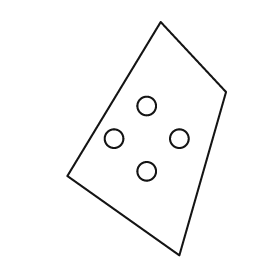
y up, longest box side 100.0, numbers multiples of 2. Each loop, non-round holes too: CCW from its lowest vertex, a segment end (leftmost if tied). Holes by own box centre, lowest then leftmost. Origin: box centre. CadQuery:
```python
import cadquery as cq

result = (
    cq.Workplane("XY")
    .moveTo(14.0, -50.0)
    .lineTo(34.0, 20.0)
    .lineTo(6.0, 50.0)
    .lineTo(-34.0, -16.0)
    .close()
    .moveTo(0.0, -14.0)
    .circle(4.0)
    .moveTo(-14.0, 0.0)
    .circle(4.0)
    .moveTo(14.0, 0.0)
    .circle(4.0)
    .moveTo(0.0, 14.0)
    .circle(4.0)
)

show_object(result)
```